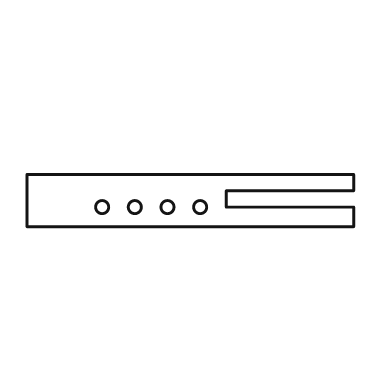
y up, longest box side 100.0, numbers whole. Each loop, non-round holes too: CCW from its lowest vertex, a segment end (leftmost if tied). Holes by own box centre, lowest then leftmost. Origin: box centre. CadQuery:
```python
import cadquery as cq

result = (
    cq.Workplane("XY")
    .moveTo(-50.0, -8.0)
    .lineTo(50.0, -8.0)
    .lineTo(50.0, -2.0)
    .lineTo(11.0, -2.0)
    .lineTo(11.0, 3.0)
    .lineTo(50.0, 3.0)
    .lineTo(50.0, 8.0)
    .lineTo(-50.0, 8.0)
    .close()
    .moveTo(-27.0, -2.0)
    .circle(2.0)
    .moveTo(-17.0, -2.0)
    .circle(2.0)
    .moveTo(-7.0, -2.0)
    .circle(2.0)
    .moveTo(3.0, -2.0)
    .circle(2.0)
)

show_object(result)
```